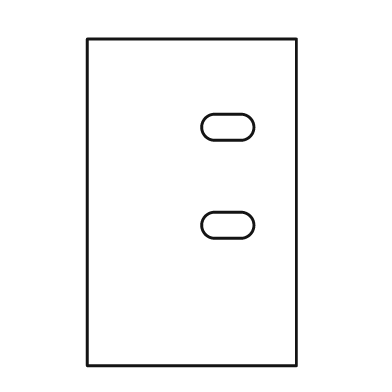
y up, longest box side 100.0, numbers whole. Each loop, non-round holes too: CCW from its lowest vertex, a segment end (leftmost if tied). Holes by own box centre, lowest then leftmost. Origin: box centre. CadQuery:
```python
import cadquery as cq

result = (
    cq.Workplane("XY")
    .moveTo(-32.0, -50.0)
    .lineTo(32.0, -50.0)
    .lineTo(32.0, 50.0)
    .lineTo(-32.0, 50.0)
    .close()
    .moveTo(7.0, -11.0)
    .lineTo(15.0, -11.0)
    .threePointArc((19.0, -7.0), (15.0, -3.0))
    .lineTo(7.0, -3.0)
    .threePointArc((3.0, -7.0), (7.0, -11.0))
    .close()
    .moveTo(7.0, 19.0)
    .lineTo(15.0, 19.0)
    .threePointArc((19.0, 23.0), (15.0, 27.0))
    .lineTo(7.0, 27.0)
    .threePointArc((3.0, 23.0), (7.0, 19.0))
    .close()
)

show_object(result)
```